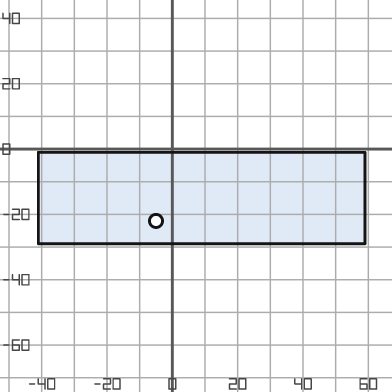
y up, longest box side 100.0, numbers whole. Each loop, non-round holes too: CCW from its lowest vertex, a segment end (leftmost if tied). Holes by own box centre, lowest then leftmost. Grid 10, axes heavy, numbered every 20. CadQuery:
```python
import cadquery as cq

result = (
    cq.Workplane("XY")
    .moveTo(-41.0, -29.0)
    .lineTo(59.0, -29.0)
    .lineTo(59.0, -1.0)
    .lineTo(-41.0, -1.0)
    .close()
    .moveTo(-5.0, -22.0)
    .circle(2.0)
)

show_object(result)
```